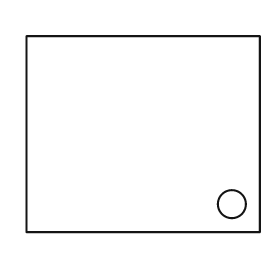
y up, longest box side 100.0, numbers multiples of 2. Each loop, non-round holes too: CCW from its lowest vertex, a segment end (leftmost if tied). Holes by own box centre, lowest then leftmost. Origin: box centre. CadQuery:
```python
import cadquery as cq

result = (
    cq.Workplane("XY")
    .moveTo(-50.0, -42.0)
    .lineTo(50.0, -42.0)
    .lineTo(50.0, 42.0)
    .lineTo(-50.0, 42.0)
    .close()
    .moveTo(38.0, -30.0)
    .circle(6.0)
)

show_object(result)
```